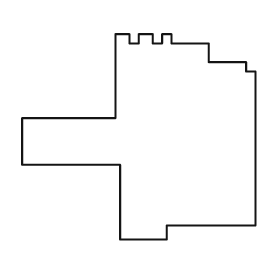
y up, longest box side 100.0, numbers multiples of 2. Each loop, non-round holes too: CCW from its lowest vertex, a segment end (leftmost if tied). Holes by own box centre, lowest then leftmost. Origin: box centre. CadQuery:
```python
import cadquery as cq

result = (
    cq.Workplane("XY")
    .moveTo(-8.0, -44.0)
    .lineTo(12.0, -44.0)
    .lineTo(12.0, -38.0)
    .lineTo(50.0, -38.0)
    .lineTo(50.0, 28.0)
    .lineTo(46.0, 28.0)
    .lineTo(46.0, 32.0)
    .lineTo(30.0, 32.0)
    .lineTo(30.0, 40.0)
    .lineTo(14.0, 40.0)
    .lineTo(14.0, 44.0)
    .lineTo(10.0, 44.0)
    .lineTo(10.0, 40.0)
    .lineTo(6.0, 40.0)
    .lineTo(6.0, 44.0)
    .lineTo(0.0, 44.0)
    .lineTo(0.0, 40.0)
    .lineTo(-4.0, 40.0)
    .lineTo(-4.0, 44.0)
    .lineTo(-10.0, 44.0)
    .lineTo(-10.0, 8.0)
    .lineTo(-50.0, 8.0)
    .lineTo(-50.0, -12.0)
    .lineTo(-8.0, -12.0)
    .close()
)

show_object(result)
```